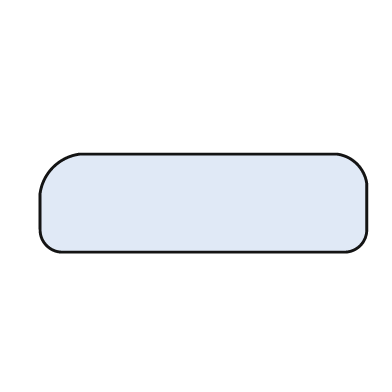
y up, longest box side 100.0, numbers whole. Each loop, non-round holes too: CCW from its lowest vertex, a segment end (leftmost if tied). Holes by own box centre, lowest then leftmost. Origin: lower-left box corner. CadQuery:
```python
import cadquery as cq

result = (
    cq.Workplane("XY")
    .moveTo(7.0, 0.0)
    .lineTo(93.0, 0.0)
    .threePointArc((98.0, 2.0), (100.0, 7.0))
    .lineTo(100.0, 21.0)
    .threePointArc((97.0, 27.0), (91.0, 30.0))
    .lineTo(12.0, 30.0)
    .threePointArc((4.0, 26.0), (0.0, 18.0))
    .lineTo(0.0, 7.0)
    .threePointArc((2.0, 2.0), (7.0, 0.0))
    .close()
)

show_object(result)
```